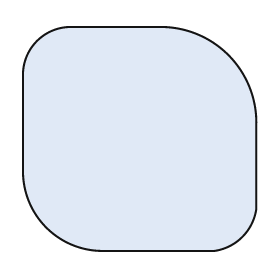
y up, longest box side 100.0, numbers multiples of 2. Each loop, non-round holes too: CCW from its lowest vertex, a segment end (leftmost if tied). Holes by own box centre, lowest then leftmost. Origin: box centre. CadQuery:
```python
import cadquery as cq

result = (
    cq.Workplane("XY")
    .moveTo(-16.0, -48.0)
    .lineTo(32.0, -48.0)
    .threePointArc((44.0, -42.0), (50.0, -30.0))
    .lineTo(50.0, 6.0)
    .threePointArc((38.0, 36.0), (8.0, 48.0))
    .lineTo(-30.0, 48.0)
    .threePointArc((-44.0, 42.0), (-50.0, 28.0))
    .lineTo(-50.0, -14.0)
    .threePointArc((-40.0, -38.0), (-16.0, -48.0))
    .close()
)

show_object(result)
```